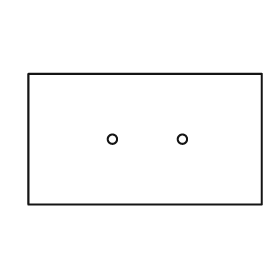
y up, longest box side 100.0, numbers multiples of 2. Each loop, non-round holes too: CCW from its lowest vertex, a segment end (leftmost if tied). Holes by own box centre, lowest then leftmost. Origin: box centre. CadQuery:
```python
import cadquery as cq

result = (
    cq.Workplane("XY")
    .moveTo(-50.0, -28.0)
    .lineTo(50.0, -28.0)
    .lineTo(50.0, 28.0)
    .lineTo(-50.0, 28.0)
    .close()
    .moveTo(-14.0, 0.0)
    .circle(2.0)
    .moveTo(16.0, 0.0)
    .circle(2.0)
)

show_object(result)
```